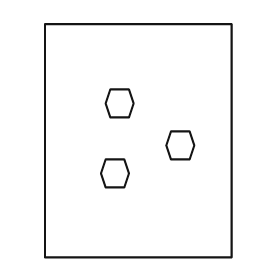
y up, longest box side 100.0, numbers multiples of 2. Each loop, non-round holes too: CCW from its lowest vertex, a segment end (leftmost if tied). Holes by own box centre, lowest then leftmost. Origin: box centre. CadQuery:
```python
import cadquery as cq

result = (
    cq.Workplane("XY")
    .moveTo(-40.0, -50.0)
    .lineTo(40.0, -50.0)
    .lineTo(40.0, 50.0)
    .lineTo(-40.0, 50.0)
    .close()
    .moveTo(-14.0, -20.0)
    .lineTo(-6.0, -20.0)
    .lineTo(-4.0, -14.0)
    .lineTo(-6.0, -8.0)
    .lineTo(-14.0, -8.0)
    .lineTo(-16.0, -14.0)
    .close()
    .moveTo(14.0, -8.0)
    .lineTo(22.0, -8.0)
    .lineTo(24.0, -2.0)
    .lineTo(22.0, 4.0)
    .lineTo(14.0, 4.0)
    .lineTo(12.0, -2.0)
    .close()
    .moveTo(-12.0, 10.0)
    .lineTo(-4.0, 10.0)
    .lineTo(-2.0, 16.0)
    .lineTo(-4.0, 22.0)
    .lineTo(-12.0, 22.0)
    .lineTo(-14.0, 16.0)
    .close()
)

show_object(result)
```